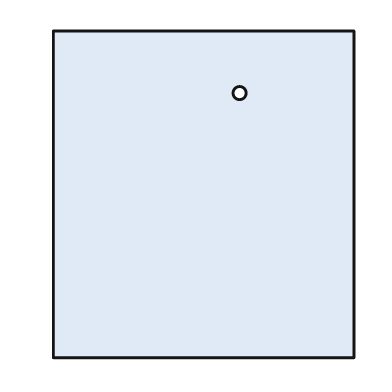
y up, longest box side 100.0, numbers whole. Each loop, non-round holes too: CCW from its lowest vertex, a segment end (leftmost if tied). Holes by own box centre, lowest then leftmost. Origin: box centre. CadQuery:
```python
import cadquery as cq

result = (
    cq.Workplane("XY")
    .moveTo(-46.0, -50.0)
    .lineTo(46.0, -50.0)
    .lineTo(46.0, 50.0)
    .lineTo(-46.0, 50.0)
    .close()
    .moveTo(11.0, 31.0)
    .circle(2.0)
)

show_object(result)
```